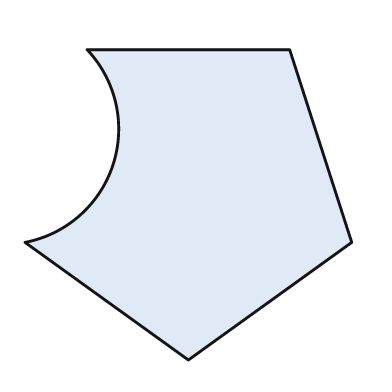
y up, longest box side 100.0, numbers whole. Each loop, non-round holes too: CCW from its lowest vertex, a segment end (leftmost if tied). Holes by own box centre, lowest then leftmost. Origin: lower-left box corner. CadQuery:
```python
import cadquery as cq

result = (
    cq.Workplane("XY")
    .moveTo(50.0, 0.0)
    .lineTo(100.0, 36.0)
    .lineTo(81.0, 95.0)
    .lineTo(19.0, 95.0)
    .threePointArc((27.0, 60.0), (0.0, 36.0))
    .close()
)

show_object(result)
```